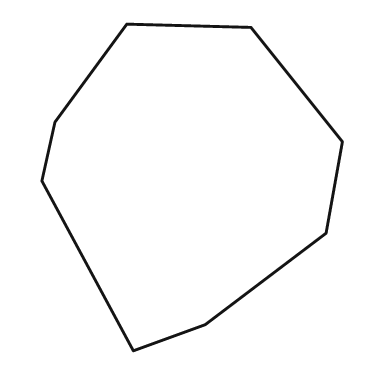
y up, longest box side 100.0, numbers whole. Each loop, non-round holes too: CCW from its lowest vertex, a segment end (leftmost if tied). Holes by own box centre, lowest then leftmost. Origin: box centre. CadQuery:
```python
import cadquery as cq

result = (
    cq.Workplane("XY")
    .moveTo(-18.0, -50.0)
    .lineTo(4.0, -42.0)
    .lineTo(41.0, -14.0)
    .lineTo(46.0, 14.0)
    .lineTo(18.0, 49.0)
    .lineTo(-20.0, 50.0)
    .lineTo(-42.0, 20.0)
    .lineTo(-46.0, 2.0)
    .close()
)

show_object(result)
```